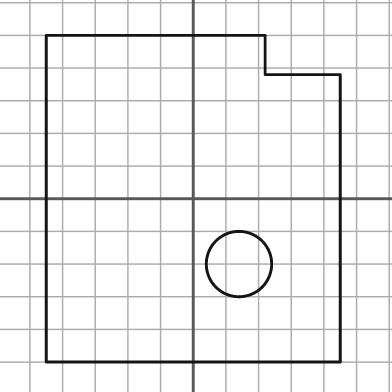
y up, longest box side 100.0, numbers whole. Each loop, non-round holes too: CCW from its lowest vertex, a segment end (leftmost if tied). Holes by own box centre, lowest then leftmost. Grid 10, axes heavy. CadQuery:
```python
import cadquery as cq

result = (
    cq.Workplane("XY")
    .moveTo(-45.0, -50.0)
    .lineTo(45.0, -50.0)
    .lineTo(45.0, 38.0)
    .lineTo(22.0, 38.0)
    .lineTo(22.0, 50.0)
    .lineTo(-45.0, 50.0)
    .close()
    .moveTo(14.0, -20.0)
    .circle(10.0)
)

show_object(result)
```